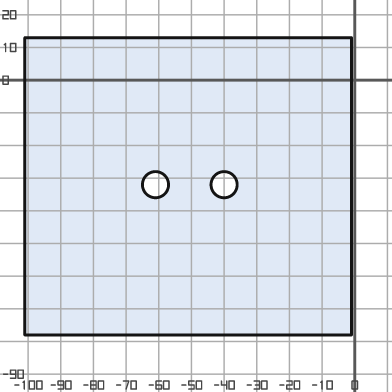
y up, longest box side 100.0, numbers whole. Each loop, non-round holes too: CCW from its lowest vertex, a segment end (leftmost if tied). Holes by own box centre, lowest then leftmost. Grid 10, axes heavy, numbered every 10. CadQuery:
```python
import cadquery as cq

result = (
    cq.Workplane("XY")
    .moveTo(-101.0, -78.0)
    .lineTo(-1.0, -78.0)
    .lineTo(-1.0, 13.0)
    .lineTo(-101.0, 13.0)
    .close()
    .moveTo(-61.0, -32.0)
    .circle(4.0)
    .moveTo(-40.0, -32.0)
    .circle(4.0)
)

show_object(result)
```